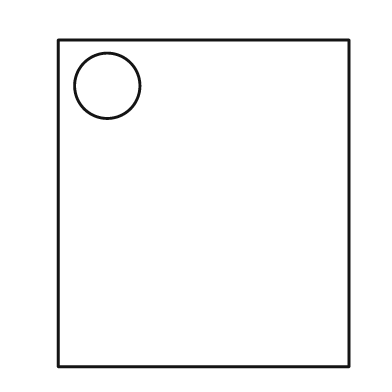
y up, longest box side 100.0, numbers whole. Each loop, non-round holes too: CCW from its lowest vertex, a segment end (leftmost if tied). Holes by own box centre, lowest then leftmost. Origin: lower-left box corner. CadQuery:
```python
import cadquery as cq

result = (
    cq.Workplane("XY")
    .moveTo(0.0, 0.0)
    .lineTo(89.0, 0.0)
    .lineTo(89.0, 100.0)
    .lineTo(0.0, 100.0)
    .close()
    .moveTo(15.0, 86.0)
    .circle(10.0)
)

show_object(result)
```